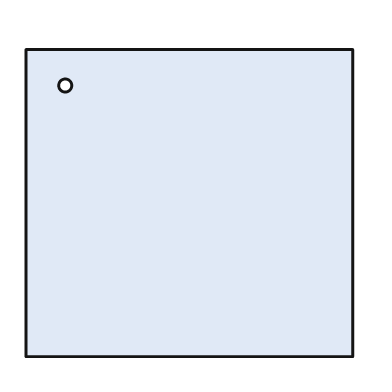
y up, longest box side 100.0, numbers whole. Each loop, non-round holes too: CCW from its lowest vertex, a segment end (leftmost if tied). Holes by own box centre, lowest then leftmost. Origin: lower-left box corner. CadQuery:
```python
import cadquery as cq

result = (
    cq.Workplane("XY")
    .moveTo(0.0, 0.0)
    .lineTo(100.0, 0.0)
    .lineTo(100.0, 94.0)
    .lineTo(0.0, 94.0)
    .close()
    .moveTo(12.0, 83.0)
    .circle(2.0)
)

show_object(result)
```